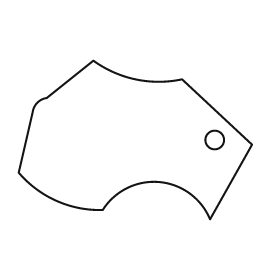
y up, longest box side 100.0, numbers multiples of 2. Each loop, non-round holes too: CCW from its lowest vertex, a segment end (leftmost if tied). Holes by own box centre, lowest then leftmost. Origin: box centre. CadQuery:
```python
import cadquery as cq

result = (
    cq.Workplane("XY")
    .moveTo(32.0, -34.0)
    .lineTo(50.0, -2.0)
    .lineTo(20.0, 26.0)
    .threePointArc((0.0, 26.0), (-18.0, 34.0))
    .lineTo(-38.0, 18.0)
    .threePointArc((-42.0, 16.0), (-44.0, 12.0))
    .lineTo(-50.0, -14.0)
    .threePointArc((-34.0, -26.0), (-14.0, -30.0))
    .threePointArc((10.0, -18.0), (32.0, -34.0))
    .close()
    .moveTo(34.0, 0.0)
    .circle(4.0)
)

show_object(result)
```